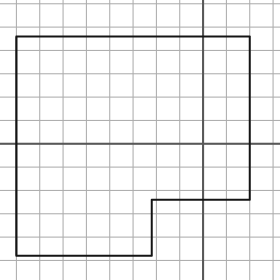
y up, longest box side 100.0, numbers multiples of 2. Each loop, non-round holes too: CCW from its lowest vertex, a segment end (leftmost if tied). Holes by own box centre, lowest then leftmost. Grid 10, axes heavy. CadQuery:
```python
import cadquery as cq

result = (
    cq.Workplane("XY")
    .moveTo(-80.0, -48.0)
    .lineTo(-22.0, -48.0)
    .lineTo(-22.0, -24.0)
    .lineTo(20.0, -24.0)
    .lineTo(20.0, 46.0)
    .lineTo(-80.0, 46.0)
    .close()
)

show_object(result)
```